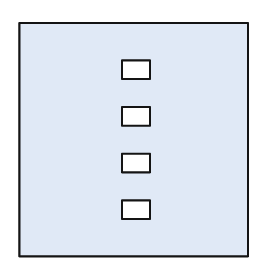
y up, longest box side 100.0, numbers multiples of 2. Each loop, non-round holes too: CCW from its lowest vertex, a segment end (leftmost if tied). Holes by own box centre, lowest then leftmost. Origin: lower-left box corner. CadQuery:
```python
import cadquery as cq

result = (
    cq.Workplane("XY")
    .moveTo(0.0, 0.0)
    .lineTo(98.0, 0.0)
    .lineTo(98.0, 100.0)
    .lineTo(0.0, 100.0)
    .close()
    .moveTo(44.0, 16.0)
    .lineTo(56.0, 16.0)
    .lineTo(56.0, 24.0)
    .lineTo(44.0, 24.0)
    .close()
    .moveTo(44.0, 36.0)
    .lineTo(56.0, 36.0)
    .lineTo(56.0, 44.0)
    .lineTo(44.0, 44.0)
    .close()
    .moveTo(44.0, 56.0)
    .lineTo(56.0, 56.0)
    .lineTo(56.0, 64.0)
    .lineTo(44.0, 64.0)
    .close()
    .moveTo(44.0, 76.0)
    .lineTo(56.0, 76.0)
    .lineTo(56.0, 84.0)
    .lineTo(44.0, 84.0)
    .close()
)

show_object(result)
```